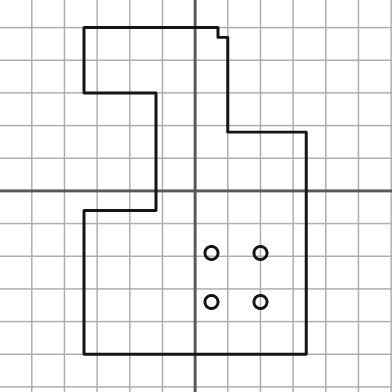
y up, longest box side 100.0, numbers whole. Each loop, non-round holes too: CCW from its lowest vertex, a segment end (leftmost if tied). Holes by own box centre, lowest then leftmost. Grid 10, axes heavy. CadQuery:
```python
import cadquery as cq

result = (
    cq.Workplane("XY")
    .moveTo(-34.0, -50.0)
    .lineTo(34.0, -50.0)
    .lineTo(34.0, 18.0)
    .lineTo(10.0, 18.0)
    .lineTo(10.0, 47.0)
    .lineTo(7.0, 47.0)
    .lineTo(7.0, 50.0)
    .lineTo(-34.0, 50.0)
    .lineTo(-34.0, 30.0)
    .lineTo(-12.0, 30.0)
    .lineTo(-12.0, -6.0)
    .lineTo(-34.0, -6.0)
    .close()
    .moveTo(5.0, -34.0)
    .circle(2.0)
    .moveTo(20.0, -34.0)
    .circle(2.0)
    .moveTo(5.0, -19.0)
    .circle(2.0)
    .moveTo(20.0, -19.0)
    .circle(2.0)
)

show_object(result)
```